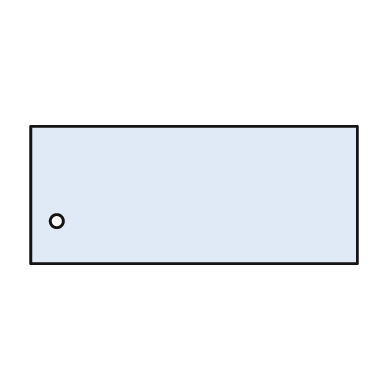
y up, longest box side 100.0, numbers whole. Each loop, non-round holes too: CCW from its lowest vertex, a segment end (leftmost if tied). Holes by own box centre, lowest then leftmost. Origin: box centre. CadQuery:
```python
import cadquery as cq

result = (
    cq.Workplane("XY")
    .moveTo(-50.0, -21.0)
    .lineTo(50.0, -21.0)
    .lineTo(50.0, 21.0)
    .lineTo(-50.0, 21.0)
    .close()
    .moveTo(-42.0, -8.0)
    .circle(2.0)
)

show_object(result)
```